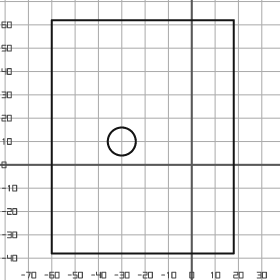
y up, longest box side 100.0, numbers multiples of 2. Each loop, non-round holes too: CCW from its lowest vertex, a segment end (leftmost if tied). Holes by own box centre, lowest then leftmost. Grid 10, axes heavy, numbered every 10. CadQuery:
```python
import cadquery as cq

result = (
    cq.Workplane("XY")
    .moveTo(-60.0, -38.0)
    .lineTo(18.0, -38.0)
    .lineTo(18.0, 62.0)
    .lineTo(-60.0, 62.0)
    .close()
    .moveTo(-30.0, 10.0)
    .circle(6.0)
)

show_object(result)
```